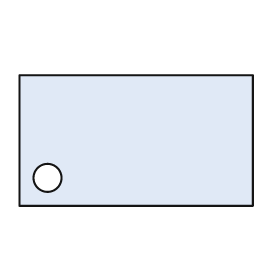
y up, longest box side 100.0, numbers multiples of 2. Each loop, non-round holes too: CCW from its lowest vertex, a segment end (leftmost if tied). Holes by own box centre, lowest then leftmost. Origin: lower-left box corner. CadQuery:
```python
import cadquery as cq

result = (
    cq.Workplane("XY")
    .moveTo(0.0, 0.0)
    .lineTo(100.0, 0.0)
    .lineTo(100.0, 56.0)
    .lineTo(0.0, 56.0)
    .close()
    .moveTo(12.0, 12.0)
    .circle(6.0)
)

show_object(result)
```